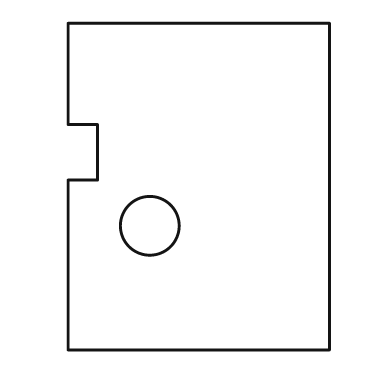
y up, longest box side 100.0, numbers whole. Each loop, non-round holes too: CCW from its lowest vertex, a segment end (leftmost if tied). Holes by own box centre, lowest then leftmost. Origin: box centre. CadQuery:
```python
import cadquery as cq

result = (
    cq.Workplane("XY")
    .moveTo(-40.0, -50.0)
    .lineTo(40.0, -50.0)
    .lineTo(40.0, 50.0)
    .lineTo(-40.0, 50.0)
    .lineTo(-40.0, 19.0)
    .lineTo(-31.0, 19.0)
    .lineTo(-31.0, 2.0)
    .lineTo(-40.0, 2.0)
    .close()
    .moveTo(-15.0, -12.0)
    .circle(9.0)
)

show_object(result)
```